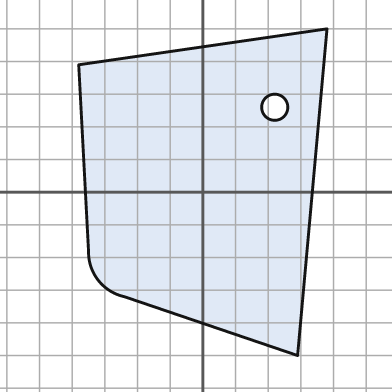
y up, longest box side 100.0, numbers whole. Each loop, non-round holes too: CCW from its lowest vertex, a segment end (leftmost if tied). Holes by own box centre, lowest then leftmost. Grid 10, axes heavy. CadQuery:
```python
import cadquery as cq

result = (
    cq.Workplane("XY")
    .moveTo(29.0, -50.0)
    .lineTo(38.0, 50.0)
    .lineTo(-38.0, 39.0)
    .lineTo(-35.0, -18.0)
    .threePointArc((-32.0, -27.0), (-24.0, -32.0))
    .close()
    .moveTo(22.0, 26.0)
    .circle(4.0)
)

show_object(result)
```